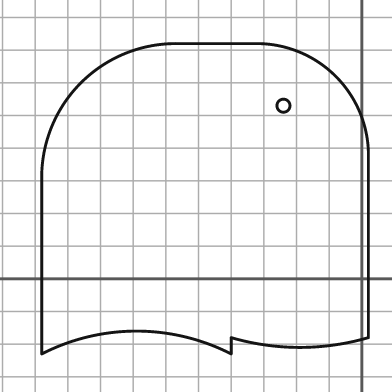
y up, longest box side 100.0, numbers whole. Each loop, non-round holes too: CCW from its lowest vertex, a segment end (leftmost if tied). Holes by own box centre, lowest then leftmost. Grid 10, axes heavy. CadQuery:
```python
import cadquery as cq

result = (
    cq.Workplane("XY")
    .moveTo(-98.0, -23.0)
    .threePointArc((-69.0, -16.0), (-40.0, -23.0))
    .lineTo(-40.0, -18.0)
    .threePointArc((-19.0, -21.0), (2.0, -18.0))
    .lineTo(2.0, 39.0)
    .threePointArc((-8.0, 62.0), (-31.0, 72.0))
    .lineTo(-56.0, 72.0)
    .threePointArc((-86.0, 60.0), (-98.0, 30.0))
    .close()
    .moveTo(-24.0, 53.0)
    .circle(2.0)
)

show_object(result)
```